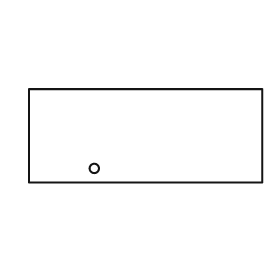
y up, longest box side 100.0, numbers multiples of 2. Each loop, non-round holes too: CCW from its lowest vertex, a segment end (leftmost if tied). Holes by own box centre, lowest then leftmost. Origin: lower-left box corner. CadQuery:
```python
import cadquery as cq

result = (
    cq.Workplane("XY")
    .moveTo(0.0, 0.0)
    .lineTo(100.0, 0.0)
    .lineTo(100.0, 40.0)
    .lineTo(0.0, 40.0)
    .close()
    .moveTo(28.0, 6.0)
    .circle(2.0)
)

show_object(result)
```